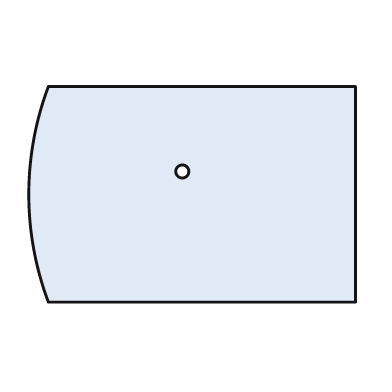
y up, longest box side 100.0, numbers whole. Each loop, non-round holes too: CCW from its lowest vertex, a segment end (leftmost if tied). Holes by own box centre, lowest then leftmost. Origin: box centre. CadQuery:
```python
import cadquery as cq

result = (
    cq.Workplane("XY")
    .moveTo(-44.0, -33.0)
    .lineTo(50.0, -33.0)
    .lineTo(50.0, 33.0)
    .lineTo(-44.0, 33.0)
    .threePointArc((-50.0, 0.0), (-44.0, -33.0))
    .close()
    .moveTo(-3.0, 7.0)
    .circle(2.0)
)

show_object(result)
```